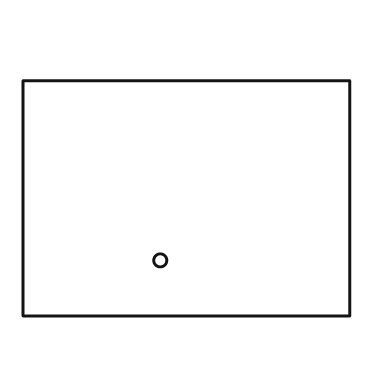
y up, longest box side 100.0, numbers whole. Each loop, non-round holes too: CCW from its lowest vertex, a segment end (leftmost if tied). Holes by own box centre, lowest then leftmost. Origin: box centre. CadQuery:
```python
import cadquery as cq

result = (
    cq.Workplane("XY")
    .moveTo(-50.0, -36.0)
    .lineTo(50.0, -36.0)
    .lineTo(50.0, 36.0)
    .lineTo(-50.0, 36.0)
    .close()
    .moveTo(-8.0, -19.0)
    .circle(2.0)
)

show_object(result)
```